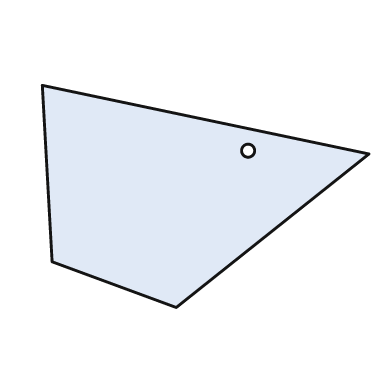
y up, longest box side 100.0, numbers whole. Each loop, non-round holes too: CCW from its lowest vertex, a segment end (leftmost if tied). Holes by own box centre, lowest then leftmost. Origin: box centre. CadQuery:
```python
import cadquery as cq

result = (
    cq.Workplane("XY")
    .moveTo(-9.0, -34.0)
    .lineTo(50.0, 13.0)
    .lineTo(-50.0, 34.0)
    .lineTo(-47.0, -20.0)
    .close()
    .moveTo(13.0, 14.0)
    .circle(2.0)
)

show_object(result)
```